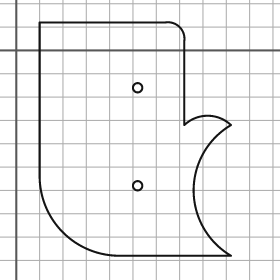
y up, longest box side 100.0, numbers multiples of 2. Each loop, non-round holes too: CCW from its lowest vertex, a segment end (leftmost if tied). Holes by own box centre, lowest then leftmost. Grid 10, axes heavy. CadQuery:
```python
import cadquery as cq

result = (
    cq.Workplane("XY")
    .moveTo(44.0, -88.0)
    .lineTo(92.0, -88.0)
    .threePointArc((76.0, -60.0), (92.0, -32.0))
    .threePointArc((82.0, -28.0), (72.0, -32.0))
    .lineTo(72.0, 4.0)
    .threePointArc((70.0, 10.0), (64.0, 12.0))
    .lineTo(10.0, 12.0)
    .lineTo(10.0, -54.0)
    .threePointArc((20.0, -78.0), (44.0, -88.0))
    .close()
    .moveTo(52.0, -58.0)
    .circle(2.0)
    .moveTo(52.0, -16.0)
    .circle(2.0)
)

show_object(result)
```